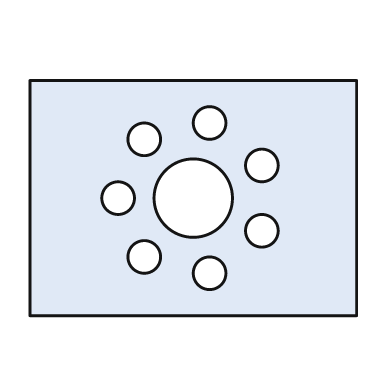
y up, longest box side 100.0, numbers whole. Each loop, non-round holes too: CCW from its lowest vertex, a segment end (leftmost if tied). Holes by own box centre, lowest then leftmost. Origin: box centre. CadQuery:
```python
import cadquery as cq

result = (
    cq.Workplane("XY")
    .moveTo(-50.0, -36.0)
    .lineTo(50.0, -36.0)
    .lineTo(50.0, 36.0)
    .lineTo(-50.0, 36.0)
    .close()
    .moveTo(5.0, -23.0)
    .circle(5.0)
    .moveTo(-15.0, -18.0)
    .circle(5.0)
    .moveTo(21.0, -10.0)
    .circle(5.0)
    .moveTo(-23.0, 0.0)
    .circle(5.0)
    .moveTo(0.0, 0.0)
    .circle(12.0)
    .moveTo(21.0, 10.0)
    .circle(5.0)
    .moveTo(-15.0, 18.0)
    .circle(5.0)
    .moveTo(5.0, 23.0)
    .circle(5.0)
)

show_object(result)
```